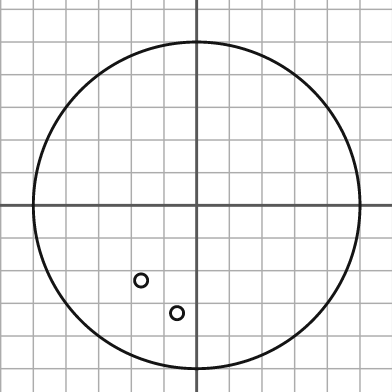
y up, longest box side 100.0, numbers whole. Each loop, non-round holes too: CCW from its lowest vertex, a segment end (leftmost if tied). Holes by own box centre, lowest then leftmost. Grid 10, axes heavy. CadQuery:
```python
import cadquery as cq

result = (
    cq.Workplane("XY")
    .moveTo(0.0, 0.0)
    .circle(50.0)
    .moveTo(-6.0, -33.0)
    .circle(2.0)
    .moveTo(-17.0, -23.0)
    .circle(2.0)
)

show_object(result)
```